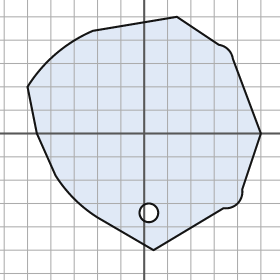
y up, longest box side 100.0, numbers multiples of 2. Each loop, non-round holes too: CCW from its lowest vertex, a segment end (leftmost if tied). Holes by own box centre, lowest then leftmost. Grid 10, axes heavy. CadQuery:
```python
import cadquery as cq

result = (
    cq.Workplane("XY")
    .moveTo(4.0, -50.0)
    .lineTo(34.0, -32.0)
    .threePointArc((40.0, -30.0), (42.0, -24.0))
    .lineTo(50.0, 0.0)
    .lineTo(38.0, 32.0)
    .threePointArc((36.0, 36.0), (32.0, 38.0))
    .lineTo(14.0, 50.0)
    .lineTo(-22.0, 44.0)
    .threePointArc((-38.0, 34.0), (-50.0, 20.0))
    .lineTo(-46.0, 0.0)
    .lineTo(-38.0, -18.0)
    .threePointArc((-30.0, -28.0), (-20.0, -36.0))
    .close()
    .moveTo(2.0, -34.0)
    .circle(4.0)
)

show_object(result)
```